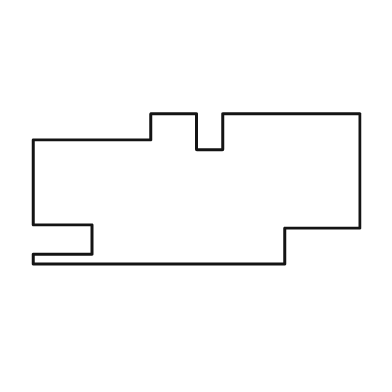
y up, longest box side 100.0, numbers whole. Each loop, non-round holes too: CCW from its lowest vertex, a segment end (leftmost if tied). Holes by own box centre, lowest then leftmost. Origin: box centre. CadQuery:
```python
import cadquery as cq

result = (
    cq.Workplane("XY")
    .moveTo(-50.0, -23.0)
    .lineTo(27.0, -23.0)
    .lineTo(27.0, -12.0)
    .lineTo(50.0, -12.0)
    .lineTo(50.0, 23.0)
    .lineTo(8.0, 23.0)
    .lineTo(8.0, 12.0)
    .lineTo(0.0, 12.0)
    .lineTo(0.0, 23.0)
    .lineTo(-14.0, 23.0)
    .lineTo(-14.0, 15.0)
    .lineTo(-50.0, 15.0)
    .lineTo(-50.0, -11.0)
    .lineTo(-32.0, -11.0)
    .lineTo(-32.0, -20.0)
    .lineTo(-50.0, -20.0)
    .close()
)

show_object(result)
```